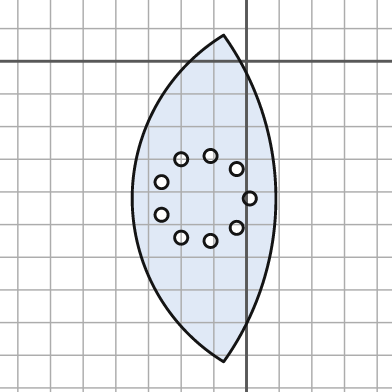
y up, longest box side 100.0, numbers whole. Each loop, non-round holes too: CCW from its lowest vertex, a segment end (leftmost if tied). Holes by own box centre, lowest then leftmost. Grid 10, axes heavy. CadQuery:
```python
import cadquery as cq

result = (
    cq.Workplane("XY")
    .moveTo(-7.0, -92.0)
    .threePointArc((9.0, -42.0), (-7.0, 8.0))
    .threePointArc((-35.0, -42.0), (-7.0, -92.0))
    .close()
    .moveTo(-11.0, -55.0)
    .circle(2.0)
    .moveTo(-20.0, -54.0)
    .circle(2.0)
    .moveTo(-3.0, -51.0)
    .circle(2.0)
    .moveTo(-26.0, -47.0)
    .circle(2.0)
    .moveTo(1.0, -42.0)
    .circle(2.0)
    .moveTo(-26.0, -37.0)
    .circle(2.0)
    .moveTo(-3.0, -33.0)
    .circle(2.0)
    .moveTo(-20.0, -30.0)
    .circle(2.0)
    .moveTo(-11.0, -29.0)
    .circle(2.0)
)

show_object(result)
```